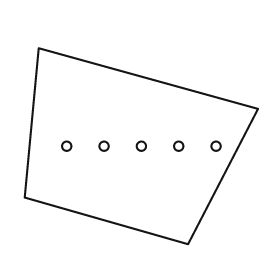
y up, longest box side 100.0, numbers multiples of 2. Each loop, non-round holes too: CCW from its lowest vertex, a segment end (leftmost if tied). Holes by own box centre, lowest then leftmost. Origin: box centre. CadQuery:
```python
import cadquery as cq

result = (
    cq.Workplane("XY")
    .moveTo(20.0, -42.0)
    .lineTo(50.0, 16.0)
    .lineTo(-44.0, 42.0)
    .lineTo(-50.0, -22.0)
    .close()
    .moveTo(-32.0, 0.0)
    .circle(2.0)
    .moveTo(-16.0, 0.0)
    .circle(2.0)
    .moveTo(0.0, 0.0)
    .circle(2.0)
    .moveTo(16.0, 0.0)
    .circle(2.0)
    .moveTo(32.0, 0.0)
    .circle(2.0)
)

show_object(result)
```